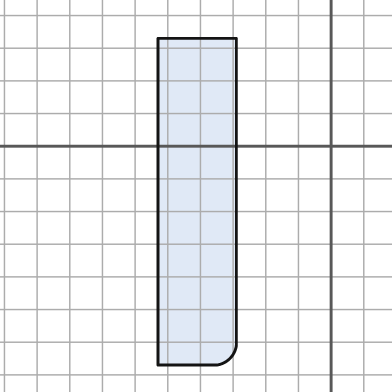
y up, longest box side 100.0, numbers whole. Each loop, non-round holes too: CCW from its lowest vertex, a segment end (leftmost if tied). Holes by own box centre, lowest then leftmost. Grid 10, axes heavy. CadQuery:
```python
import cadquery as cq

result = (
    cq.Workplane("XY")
    .moveTo(-53.0, -67.0)
    .lineTo(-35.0, -67.0)
    .threePointArc((-31.0, -65.0), (-29.0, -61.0))
    .lineTo(-29.0, 33.0)
    .lineTo(-53.0, 33.0)
    .close()
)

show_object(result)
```